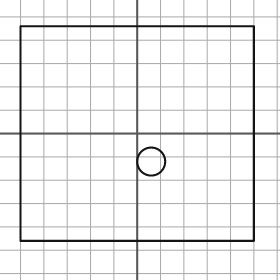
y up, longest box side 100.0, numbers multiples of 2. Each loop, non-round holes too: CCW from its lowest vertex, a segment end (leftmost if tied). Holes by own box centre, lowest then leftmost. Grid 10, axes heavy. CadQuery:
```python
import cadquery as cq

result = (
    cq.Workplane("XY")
    .moveTo(-50.0, -46.0)
    .lineTo(50.0, -46.0)
    .lineTo(50.0, 46.0)
    .lineTo(-50.0, 46.0)
    .close()
    .moveTo(6.0, -12.0)
    .circle(6.0)
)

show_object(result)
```